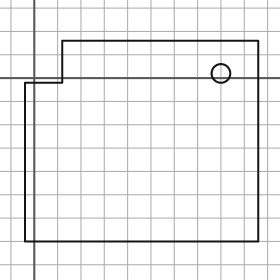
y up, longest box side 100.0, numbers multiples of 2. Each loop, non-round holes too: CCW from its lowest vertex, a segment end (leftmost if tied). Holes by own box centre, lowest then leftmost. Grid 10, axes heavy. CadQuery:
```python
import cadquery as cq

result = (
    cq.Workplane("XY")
    .moveTo(-4.0, -70.0)
    .lineTo(96.0, -70.0)
    .lineTo(96.0, 16.0)
    .lineTo(12.0, 16.0)
    .lineTo(12.0, -2.0)
    .lineTo(-4.0, -2.0)
    .close()
    .moveTo(80.0, 2.0)
    .circle(4.0)
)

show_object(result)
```